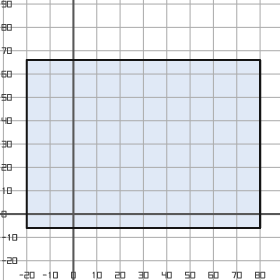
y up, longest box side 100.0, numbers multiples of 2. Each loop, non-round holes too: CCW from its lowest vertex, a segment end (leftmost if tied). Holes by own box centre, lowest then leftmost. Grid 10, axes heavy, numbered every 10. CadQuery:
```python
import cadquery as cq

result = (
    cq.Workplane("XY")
    .moveTo(-20.0, -6.0)
    .lineTo(80.0, -6.0)
    .lineTo(80.0, 66.0)
    .lineTo(-20.0, 66.0)
    .close()
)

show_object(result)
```